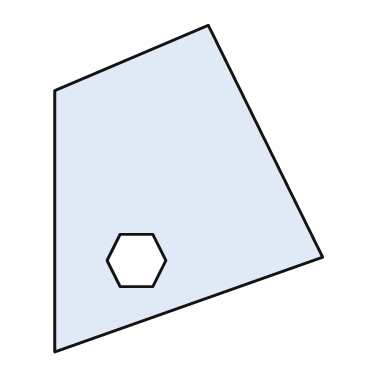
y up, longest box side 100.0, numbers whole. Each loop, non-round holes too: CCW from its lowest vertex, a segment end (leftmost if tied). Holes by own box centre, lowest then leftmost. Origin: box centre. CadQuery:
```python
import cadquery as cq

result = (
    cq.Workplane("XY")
    .moveTo(-41.0, -50.0)
    .lineTo(41.0, -21.0)
    .lineTo(6.0, 50.0)
    .lineTo(-41.0, 30.0)
    .close()
    .moveTo(-21.0, -30.0)
    .lineTo(-11.0, -30.0)
    .lineTo(-7.0, -22.0)
    .lineTo(-11.0, -14.0)
    .lineTo(-21.0, -14.0)
    .lineTo(-25.0, -22.0)
    .close()
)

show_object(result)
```